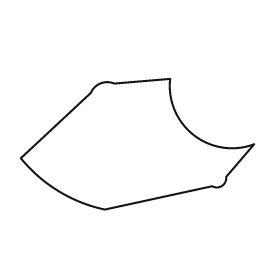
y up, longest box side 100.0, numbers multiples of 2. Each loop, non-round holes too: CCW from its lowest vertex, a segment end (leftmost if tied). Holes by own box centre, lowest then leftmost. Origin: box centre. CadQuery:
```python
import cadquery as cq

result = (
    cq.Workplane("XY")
    .moveTo(-14.0, -28.0)
    .lineTo(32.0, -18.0)
    .threePointArc((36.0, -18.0), (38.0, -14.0))
    .lineTo(50.0, 0.0)
    .threePointArc((24.0, 4.0), (14.0, 28.0))
    .lineTo(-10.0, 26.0)
    .threePointArc((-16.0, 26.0), (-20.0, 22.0))
    .lineTo(-50.0, -6.0)
    .threePointArc((-34.0, -20.0), (-14.0, -28.0))
    .close()
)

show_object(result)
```